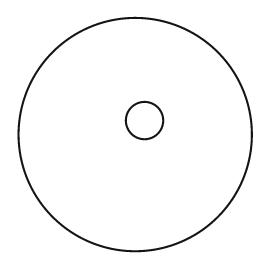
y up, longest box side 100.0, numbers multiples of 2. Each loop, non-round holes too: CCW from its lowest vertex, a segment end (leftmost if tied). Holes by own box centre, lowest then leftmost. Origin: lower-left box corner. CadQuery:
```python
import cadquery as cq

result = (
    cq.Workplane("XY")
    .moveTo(50.0, 50.0)
    .circle(50.0)
    .moveTo(54.0, 56.0)
    .circle(8.0)
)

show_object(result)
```